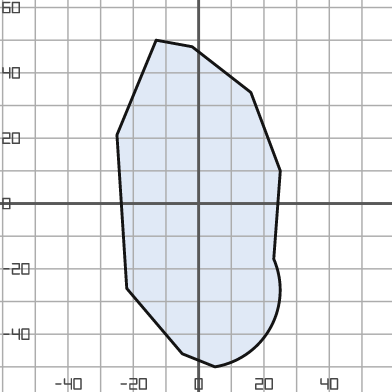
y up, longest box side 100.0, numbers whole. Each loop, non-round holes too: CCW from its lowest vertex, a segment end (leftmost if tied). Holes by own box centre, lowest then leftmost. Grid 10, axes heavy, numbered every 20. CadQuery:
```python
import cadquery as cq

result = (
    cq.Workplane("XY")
    .moveTo(5.0, -50.0)
    .threePointArc((22.0, -38.0), (23.0, -17.0))
    .lineTo(25.0, 10.0)
    .lineTo(16.0, 34.0)
    .lineTo(-2.0, 48.0)
    .lineTo(-13.0, 50.0)
    .lineTo(-25.0, 21.0)
    .lineTo(-22.0, -26.0)
    .lineTo(-5.0, -46.0)
    .close()
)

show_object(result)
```